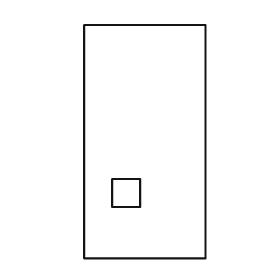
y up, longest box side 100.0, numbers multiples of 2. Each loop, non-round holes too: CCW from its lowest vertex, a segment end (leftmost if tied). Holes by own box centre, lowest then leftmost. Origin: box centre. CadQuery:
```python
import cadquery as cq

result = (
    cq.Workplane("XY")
    .moveTo(-26.0, -50.0)
    .lineTo(26.0, -50.0)
    .lineTo(26.0, 50.0)
    .lineTo(-26.0, 50.0)
    .close()
    .moveTo(-14.0, -28.0)
    .lineTo(-2.0, -28.0)
    .lineTo(-2.0, -16.0)
    .lineTo(-14.0, -16.0)
    .close()
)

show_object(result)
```